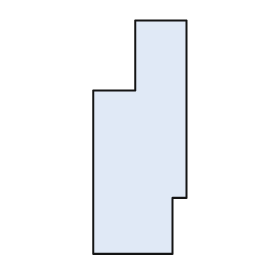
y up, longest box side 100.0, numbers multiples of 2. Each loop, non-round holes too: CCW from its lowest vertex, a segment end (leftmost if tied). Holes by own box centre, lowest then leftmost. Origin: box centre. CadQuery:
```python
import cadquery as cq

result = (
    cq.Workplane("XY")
    .moveTo(-20.0, -50.0)
    .lineTo(14.0, -50.0)
    .lineTo(14.0, -26.0)
    .lineTo(20.0, -26.0)
    .lineTo(20.0, 50.0)
    .lineTo(-2.0, 50.0)
    .lineTo(-2.0, 20.0)
    .lineTo(-20.0, 20.0)
    .close()
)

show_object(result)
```